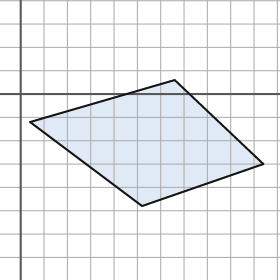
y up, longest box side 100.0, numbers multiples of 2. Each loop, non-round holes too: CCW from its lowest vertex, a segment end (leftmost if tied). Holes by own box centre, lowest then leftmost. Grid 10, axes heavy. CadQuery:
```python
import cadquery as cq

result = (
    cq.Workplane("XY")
    .moveTo(52.0, -48.0)
    .lineTo(104.0, -30.0)
    .lineTo(66.0, 6.0)
    .lineTo(4.0, -12.0)
    .close()
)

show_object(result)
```